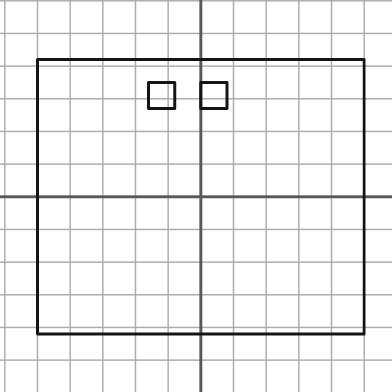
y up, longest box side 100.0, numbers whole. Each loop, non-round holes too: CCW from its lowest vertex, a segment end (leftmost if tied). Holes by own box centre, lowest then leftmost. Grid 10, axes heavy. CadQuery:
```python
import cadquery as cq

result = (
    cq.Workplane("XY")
    .moveTo(-50.0, -42.0)
    .lineTo(50.0, -42.0)
    .lineTo(50.0, 42.0)
    .lineTo(-50.0, 42.0)
    .close()
    .moveTo(-16.0, 27.0)
    .lineTo(-8.0, 27.0)
    .lineTo(-8.0, 35.0)
    .lineTo(-16.0, 35.0)
    .close()
    .moveTo(0.0, 27.0)
    .lineTo(8.0, 27.0)
    .lineTo(8.0, 35.0)
    .lineTo(0.0, 35.0)
    .close()
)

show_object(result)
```